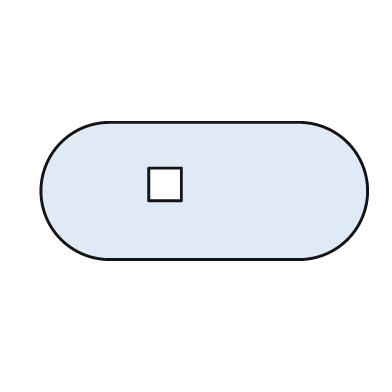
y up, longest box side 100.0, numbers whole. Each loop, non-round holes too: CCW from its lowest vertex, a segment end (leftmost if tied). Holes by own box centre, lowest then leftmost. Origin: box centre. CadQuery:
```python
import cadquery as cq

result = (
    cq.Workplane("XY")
    .moveTo(-29.0, -21.0)
    .lineTo(29.0, -21.0)
    .threePointArc((50.0, 0.0), (29.0, 21.0))
    .lineTo(-29.0, 21.0)
    .threePointArc((-50.0, 0.0), (-29.0, -21.0))
    .close()
    .moveTo(-17.0, -3.0)
    .lineTo(-7.0, -3.0)
    .lineTo(-7.0, 7.0)
    .lineTo(-17.0, 7.0)
    .close()
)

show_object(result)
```